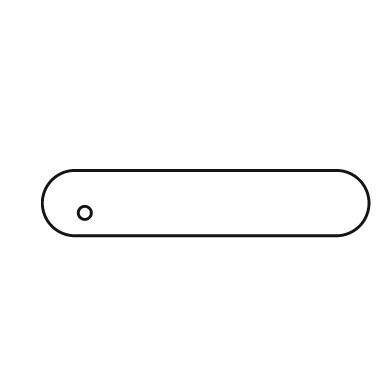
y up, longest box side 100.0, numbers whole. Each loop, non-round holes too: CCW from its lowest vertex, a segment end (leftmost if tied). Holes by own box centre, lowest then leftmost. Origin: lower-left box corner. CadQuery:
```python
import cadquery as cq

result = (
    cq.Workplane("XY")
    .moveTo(10.0, 0.0)
    .lineTo(90.0, 0.0)
    .threePointArc((100.0, 10.0), (90.0, 20.0))
    .lineTo(10.0, 20.0)
    .threePointArc((0.0, 10.0), (10.0, 0.0))
    .close()
    .moveTo(13.0, 7.0)
    .circle(2.0)
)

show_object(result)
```